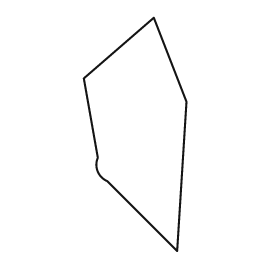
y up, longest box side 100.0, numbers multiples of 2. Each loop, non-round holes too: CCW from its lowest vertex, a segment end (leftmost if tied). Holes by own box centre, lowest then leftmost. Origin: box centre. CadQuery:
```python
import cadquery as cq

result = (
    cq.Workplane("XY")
    .moveTo(18.0, -50.0)
    .lineTo(22.0, 14.0)
    .lineTo(8.0, 50.0)
    .lineTo(-22.0, 24.0)
    .lineTo(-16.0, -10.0)
    .threePointArc((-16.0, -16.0), (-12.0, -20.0))
    .close()
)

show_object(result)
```